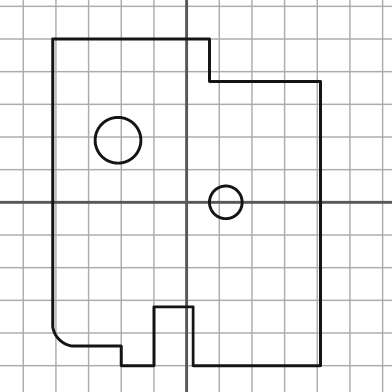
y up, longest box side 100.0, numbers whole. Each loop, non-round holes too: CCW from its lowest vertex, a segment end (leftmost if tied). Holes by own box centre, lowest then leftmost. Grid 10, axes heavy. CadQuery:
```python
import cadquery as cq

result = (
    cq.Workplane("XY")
    .moveTo(-20.0, -50.0)
    .lineTo(-10.0, -50.0)
    .lineTo(-10.0, -32.0)
    .lineTo(2.0, -32.0)
    .lineTo(2.0, -50.0)
    .lineTo(41.0, -50.0)
    .lineTo(41.0, 37.0)
    .lineTo(7.0, 37.0)
    .lineTo(7.0, 50.0)
    .lineTo(-41.0, 50.0)
    .lineTo(-41.0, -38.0)
    .threePointArc((-39.0, -42.0), (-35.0, -44.0))
    .lineTo(-20.0, -44.0)
    .close()
    .moveTo(12.0, 0.0)
    .circle(5.0)
    .moveTo(-21.0, 19.0)
    .circle(7.0)
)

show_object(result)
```